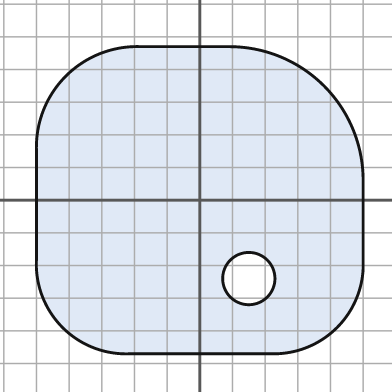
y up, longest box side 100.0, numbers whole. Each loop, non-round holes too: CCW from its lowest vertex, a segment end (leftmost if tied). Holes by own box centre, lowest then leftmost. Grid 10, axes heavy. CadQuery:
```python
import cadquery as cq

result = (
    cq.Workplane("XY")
    .moveTo(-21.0, -47.0)
    .lineTo(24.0, -47.0)
    .threePointArc((42.0, -39.0), (50.0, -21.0))
    .lineTo(50.0, 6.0)
    .threePointArc((38.0, 35.0), (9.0, 47.0))
    .lineTo(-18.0, 47.0)
    .threePointArc((-41.0, 38.0), (-50.0, 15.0))
    .lineTo(-50.0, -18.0)
    .threePointArc((-42.0, -39.0), (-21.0, -47.0))
    .close()
    .moveTo(15.0, -24.0)
    .circle(8.0)
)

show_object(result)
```